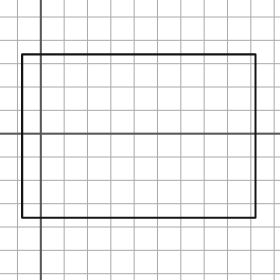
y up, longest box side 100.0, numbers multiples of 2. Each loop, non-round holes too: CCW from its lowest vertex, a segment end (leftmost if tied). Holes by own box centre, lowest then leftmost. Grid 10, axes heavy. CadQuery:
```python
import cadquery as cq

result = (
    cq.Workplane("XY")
    .moveTo(-8.0, -36.0)
    .lineTo(92.0, -36.0)
    .lineTo(92.0, 34.0)
    .lineTo(-8.0, 34.0)
    .close()
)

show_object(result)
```